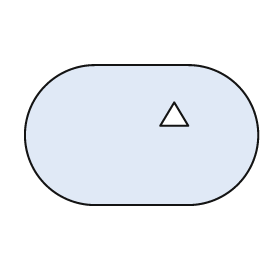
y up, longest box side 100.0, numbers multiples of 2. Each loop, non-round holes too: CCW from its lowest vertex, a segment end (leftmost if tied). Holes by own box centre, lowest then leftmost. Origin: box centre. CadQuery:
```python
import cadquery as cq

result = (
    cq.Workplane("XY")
    .moveTo(-20.0, -30.0)
    .lineTo(20.0, -30.0)
    .threePointArc((50.0, 0.0), (20.0, 30.0))
    .lineTo(-20.0, 30.0)
    .threePointArc((-50.0, 0.0), (-20.0, -30.0))
    .close()
    .moveTo(8.0, 4.0)
    .lineTo(20.0, 4.0)
    .lineTo(14.0, 14.0)
    .close()
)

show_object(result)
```